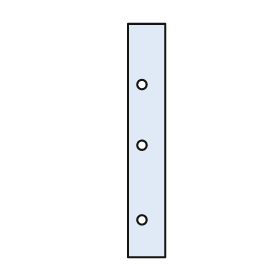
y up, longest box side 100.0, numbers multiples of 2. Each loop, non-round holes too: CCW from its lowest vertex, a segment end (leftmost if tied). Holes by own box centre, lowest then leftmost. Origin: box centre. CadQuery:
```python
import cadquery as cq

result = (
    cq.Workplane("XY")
    .moveTo(-8.0, -50.0)
    .lineTo(8.0, -50.0)
    .lineTo(8.0, 50.0)
    .lineTo(-8.0, 50.0)
    .close()
    .moveTo(-2.0, -34.0)
    .circle(2.0)
    .moveTo(-2.0, -2.0)
    .circle(2.0)
    .moveTo(-2.0, 24.0)
    .circle(2.0)
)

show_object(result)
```